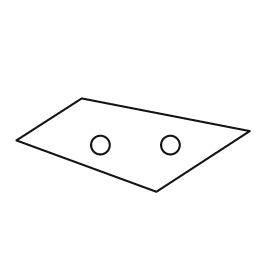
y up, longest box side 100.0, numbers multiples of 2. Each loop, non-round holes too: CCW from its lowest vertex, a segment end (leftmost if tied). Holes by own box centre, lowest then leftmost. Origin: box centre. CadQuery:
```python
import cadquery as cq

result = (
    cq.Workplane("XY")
    .moveTo(10.0, -20.0)
    .lineTo(50.0, 6.0)
    .lineTo(-22.0, 20.0)
    .lineTo(-50.0, 2.0)
    .close()
    .moveTo(-14.0, 0.0)
    .circle(4.0)
    .moveTo(16.0, 0.0)
    .circle(4.0)
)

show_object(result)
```